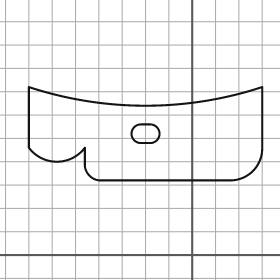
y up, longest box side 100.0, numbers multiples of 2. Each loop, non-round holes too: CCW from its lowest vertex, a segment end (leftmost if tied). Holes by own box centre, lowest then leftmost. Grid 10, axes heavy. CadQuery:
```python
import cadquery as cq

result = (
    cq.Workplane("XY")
    .moveTo(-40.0, 32.0)
    .lineTo(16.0, 32.0)
    .threePointArc((26.0, 36.0), (30.0, 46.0))
    .lineTo(30.0, 72.0)
    .threePointArc((-20.0, 64.0), (-70.0, 72.0))
    .lineTo(-70.0, 46.0)
    .threePointArc((-58.0, 40.0), (-46.0, 46.0))
    .lineTo(-46.0, 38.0)
    .threePointArc((-44.0, 34.0), (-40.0, 32.0))
    .close()
    .moveTo(-22.0, 48.0)
    .lineTo(-18.0, 48.0)
    .threePointArc((-14.0, 52.0), (-18.0, 56.0))
    .lineTo(-22.0, 56.0)
    .threePointArc((-26.0, 52.0), (-22.0, 48.0))
    .close()
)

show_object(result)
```